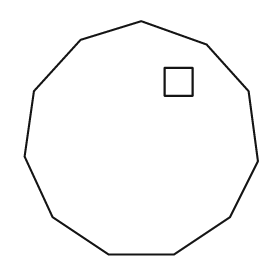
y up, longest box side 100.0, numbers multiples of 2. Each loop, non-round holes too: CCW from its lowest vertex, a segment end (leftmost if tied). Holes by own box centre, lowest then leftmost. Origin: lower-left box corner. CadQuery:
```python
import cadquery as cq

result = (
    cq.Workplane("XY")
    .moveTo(36.0, 0.0)
    .lineTo(64.0, 0.0)
    .lineTo(88.0, 16.0)
    .lineTo(100.0, 40.0)
    .lineTo(96.0, 70.0)
    .lineTo(78.0, 90.0)
    .lineTo(50.0, 100.0)
    .lineTo(24.0, 92.0)
    .lineTo(4.0, 70.0)
    .lineTo(0.0, 42.0)
    .lineTo(12.0, 16.0)
    .close()
    .moveTo(60.0, 68.0)
    .lineTo(72.0, 68.0)
    .lineTo(72.0, 80.0)
    .lineTo(60.0, 80.0)
    .close()
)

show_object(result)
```